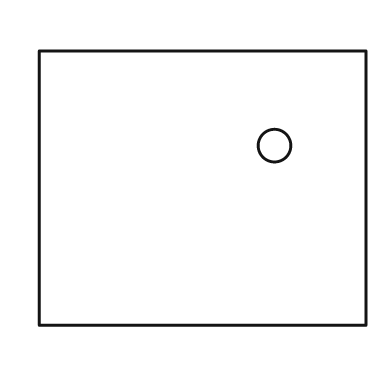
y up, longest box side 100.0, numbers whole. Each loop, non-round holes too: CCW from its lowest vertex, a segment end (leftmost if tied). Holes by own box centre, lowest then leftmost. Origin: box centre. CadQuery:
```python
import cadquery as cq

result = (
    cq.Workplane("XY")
    .moveTo(-50.0, -42.0)
    .lineTo(50.0, -42.0)
    .lineTo(50.0, 42.0)
    .lineTo(-50.0, 42.0)
    .close()
    .moveTo(22.0, 13.0)
    .circle(5.0)
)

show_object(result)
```